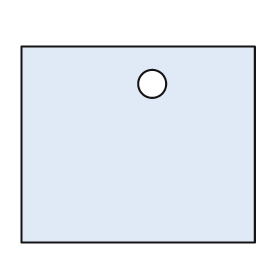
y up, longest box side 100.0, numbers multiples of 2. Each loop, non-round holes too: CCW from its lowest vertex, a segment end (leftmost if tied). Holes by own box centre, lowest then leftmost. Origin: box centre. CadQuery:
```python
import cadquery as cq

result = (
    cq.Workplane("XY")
    .moveTo(-50.0, -42.0)
    .lineTo(50.0, -42.0)
    .lineTo(50.0, 42.0)
    .lineTo(-50.0, 42.0)
    .close()
    .moveTo(6.0, 26.0)
    .circle(6.0)
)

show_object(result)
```